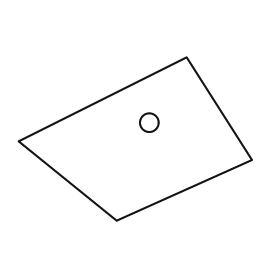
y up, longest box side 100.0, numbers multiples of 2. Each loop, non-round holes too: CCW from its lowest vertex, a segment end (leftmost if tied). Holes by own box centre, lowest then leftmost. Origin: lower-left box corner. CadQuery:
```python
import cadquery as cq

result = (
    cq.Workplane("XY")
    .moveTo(42.0, 0.0)
    .lineTo(100.0, 26.0)
    .lineTo(72.0, 70.0)
    .lineTo(0.0, 34.0)
    .close()
    .moveTo(56.0, 42.0)
    .circle(4.0)
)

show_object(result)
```